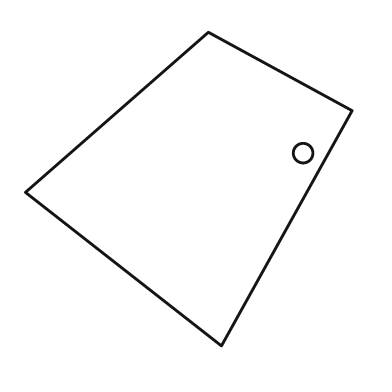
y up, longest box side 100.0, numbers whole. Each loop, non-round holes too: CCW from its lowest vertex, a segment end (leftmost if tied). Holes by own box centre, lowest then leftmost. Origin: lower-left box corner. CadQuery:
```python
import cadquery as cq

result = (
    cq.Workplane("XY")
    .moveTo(60.0, 0.0)
    .lineTo(100.0, 72.0)
    .lineTo(56.0, 96.0)
    .lineTo(0.0, 47.0)
    .close()
    .moveTo(85.0, 59.0)
    .circle(3.0)
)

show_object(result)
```